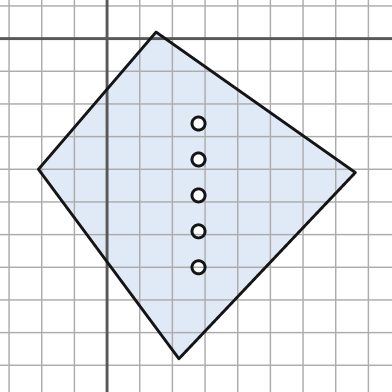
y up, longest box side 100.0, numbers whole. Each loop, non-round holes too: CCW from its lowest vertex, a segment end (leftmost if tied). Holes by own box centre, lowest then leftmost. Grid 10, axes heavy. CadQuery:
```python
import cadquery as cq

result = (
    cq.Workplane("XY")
    .moveTo(22.0, -98.0)
    .lineTo(76.0, -41.0)
    .lineTo(15.0, 2.0)
    .lineTo(-21.0, -40.0)
    .close()
    .moveTo(28.0, -70.0)
    .circle(2.0)
    .moveTo(28.0, -59.0)
    .circle(2.0)
    .moveTo(28.0, -48.0)
    .circle(2.0)
    .moveTo(28.0, -37.0)
    .circle(2.0)
    .moveTo(28.0, -26.0)
    .circle(2.0)
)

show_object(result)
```